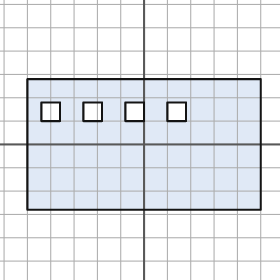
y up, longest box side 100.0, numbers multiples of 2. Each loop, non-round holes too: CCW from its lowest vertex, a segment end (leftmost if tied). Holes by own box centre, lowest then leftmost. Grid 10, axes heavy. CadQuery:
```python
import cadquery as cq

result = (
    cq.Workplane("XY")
    .moveTo(-50.0, -28.0)
    .lineTo(50.0, -28.0)
    .lineTo(50.0, 28.0)
    .lineTo(-50.0, 28.0)
    .close()
    .moveTo(-44.0, 10.0)
    .lineTo(-36.0, 10.0)
    .lineTo(-36.0, 18.0)
    .lineTo(-44.0, 18.0)
    .close()
    .moveTo(-26.0, 10.0)
    .lineTo(-18.0, 10.0)
    .lineTo(-18.0, 18.0)
    .lineTo(-26.0, 18.0)
    .close()
    .moveTo(-8.0, 10.0)
    .lineTo(0.0, 10.0)
    .lineTo(0.0, 18.0)
    .lineTo(-8.0, 18.0)
    .close()
    .moveTo(10.0, 10.0)
    .lineTo(18.0, 10.0)
    .lineTo(18.0, 18.0)
    .lineTo(10.0, 18.0)
    .close()
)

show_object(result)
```